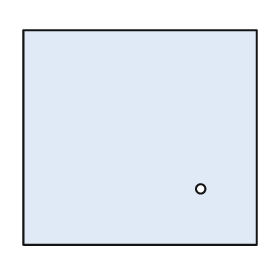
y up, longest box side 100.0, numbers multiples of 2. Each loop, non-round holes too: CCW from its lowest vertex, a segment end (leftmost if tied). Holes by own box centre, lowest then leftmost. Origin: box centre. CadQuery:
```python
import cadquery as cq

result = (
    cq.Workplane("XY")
    .moveTo(-50.0, -46.0)
    .lineTo(50.0, -46.0)
    .lineTo(50.0, 46.0)
    .lineTo(-50.0, 46.0)
    .close()
    .moveTo(26.0, -22.0)
    .circle(2.0)
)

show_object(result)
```